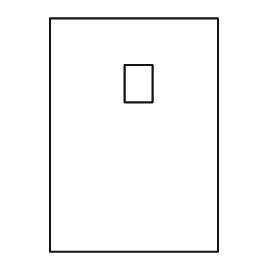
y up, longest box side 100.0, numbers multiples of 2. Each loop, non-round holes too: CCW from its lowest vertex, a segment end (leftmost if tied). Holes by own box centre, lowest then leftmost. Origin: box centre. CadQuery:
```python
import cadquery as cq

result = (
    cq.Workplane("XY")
    .moveTo(-36.0, -50.0)
    .lineTo(36.0, -50.0)
    .lineTo(36.0, 50.0)
    .lineTo(-36.0, 50.0)
    .close()
    .moveTo(-4.0, 14.0)
    .lineTo(8.0, 14.0)
    .lineTo(8.0, 30.0)
    .lineTo(-4.0, 30.0)
    .close()
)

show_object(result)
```